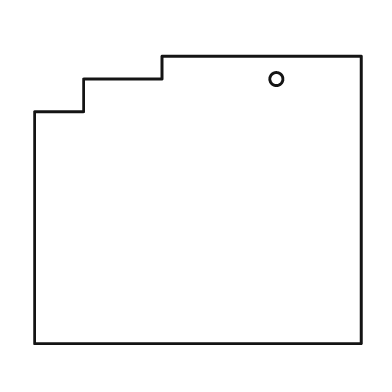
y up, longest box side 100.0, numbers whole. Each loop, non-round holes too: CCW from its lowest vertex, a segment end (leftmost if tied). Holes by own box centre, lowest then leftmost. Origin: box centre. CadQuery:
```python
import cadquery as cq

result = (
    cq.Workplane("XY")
    .moveTo(-50.0, -44.0)
    .lineTo(50.0, -44.0)
    .lineTo(50.0, 44.0)
    .lineTo(-11.0, 44.0)
    .lineTo(-11.0, 37.0)
    .lineTo(-35.0, 37.0)
    .lineTo(-35.0, 27.0)
    .lineTo(-50.0, 27.0)
    .close()
    .moveTo(24.0, 37.0)
    .circle(2.0)
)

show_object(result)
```